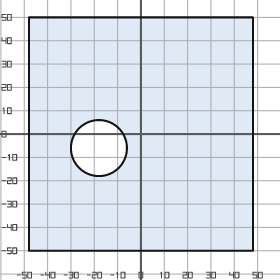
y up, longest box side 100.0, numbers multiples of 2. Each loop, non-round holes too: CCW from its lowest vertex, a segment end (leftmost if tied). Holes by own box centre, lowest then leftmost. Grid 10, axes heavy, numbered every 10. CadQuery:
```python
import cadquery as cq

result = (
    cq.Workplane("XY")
    .moveTo(-48.0, -50.0)
    .lineTo(48.0, -50.0)
    .lineTo(48.0, 50.0)
    .lineTo(-48.0, 50.0)
    .close()
    .moveTo(-18.0, -6.0)
    .circle(12.0)
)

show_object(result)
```